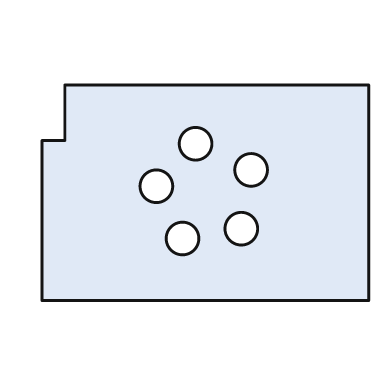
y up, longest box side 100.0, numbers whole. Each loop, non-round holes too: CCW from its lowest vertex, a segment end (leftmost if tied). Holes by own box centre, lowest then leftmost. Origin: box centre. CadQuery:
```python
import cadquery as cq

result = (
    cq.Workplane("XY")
    .moveTo(-50.0, -33.0)
    .lineTo(50.0, -33.0)
    .lineTo(50.0, 33.0)
    .lineTo(-43.0, 33.0)
    .lineTo(-43.0, 16.0)
    .lineTo(-50.0, 16.0)
    .close()
    .moveTo(-7.0, -14.0)
    .circle(5.0)
    .moveTo(11.0, -11.0)
    .circle(5.0)
    .moveTo(-15.0, 2.0)
    .circle(5.0)
    .moveTo(14.0, 7.0)
    .circle(5.0)
    .moveTo(-3.0, 15.0)
    .circle(5.0)
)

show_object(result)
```